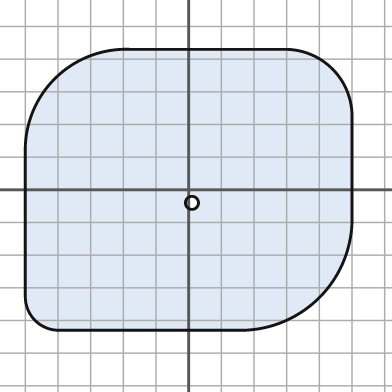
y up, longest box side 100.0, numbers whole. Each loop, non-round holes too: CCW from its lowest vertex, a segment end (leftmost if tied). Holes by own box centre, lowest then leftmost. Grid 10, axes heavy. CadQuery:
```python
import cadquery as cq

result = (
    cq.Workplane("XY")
    .moveTo(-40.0, -43.0)
    .lineTo(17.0, -43.0)
    .threePointArc((40.0, -33.0), (50.0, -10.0))
    .lineTo(50.0, 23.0)
    .threePointArc((44.0, 37.0), (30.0, 43.0))
    .lineTo(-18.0, 43.0)
    .threePointArc((-41.0, 34.0), (-50.0, 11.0))
    .lineTo(-50.0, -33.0)
    .threePointArc((-47.0, -40.0), (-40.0, -43.0))
    .close()
    .moveTo(1.0, -4.0)
    .circle(2.0)
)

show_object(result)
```